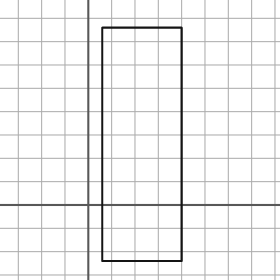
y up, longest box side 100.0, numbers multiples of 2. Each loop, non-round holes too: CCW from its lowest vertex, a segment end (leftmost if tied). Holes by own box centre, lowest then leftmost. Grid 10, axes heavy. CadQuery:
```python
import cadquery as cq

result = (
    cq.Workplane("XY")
    .moveTo(6.0, -24.0)
    .lineTo(40.0, -24.0)
    .lineTo(40.0, 76.0)
    .lineTo(6.0, 76.0)
    .close()
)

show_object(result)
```